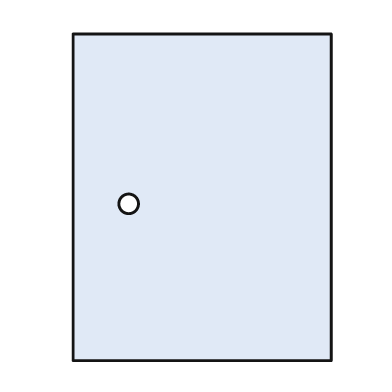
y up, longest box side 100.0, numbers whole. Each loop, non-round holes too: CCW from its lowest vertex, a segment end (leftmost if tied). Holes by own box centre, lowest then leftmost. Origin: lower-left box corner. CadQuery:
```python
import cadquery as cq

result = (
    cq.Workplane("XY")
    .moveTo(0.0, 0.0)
    .lineTo(79.0, 0.0)
    .lineTo(79.0, 100.0)
    .lineTo(0.0, 100.0)
    .close()
    .moveTo(17.0, 48.0)
    .circle(3.0)
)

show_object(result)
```